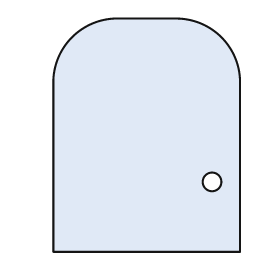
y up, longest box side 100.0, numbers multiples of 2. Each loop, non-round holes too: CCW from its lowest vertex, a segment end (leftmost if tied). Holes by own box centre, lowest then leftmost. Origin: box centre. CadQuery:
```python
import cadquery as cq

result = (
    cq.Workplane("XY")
    .moveTo(-40.0, -50.0)
    .lineTo(40.0, -50.0)
    .lineTo(40.0, 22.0)
    .threePointArc((32.0, 42.0), (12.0, 50.0))
    .lineTo(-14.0, 50.0)
    .threePointArc((-32.0, 42.0), (-40.0, 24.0))
    .close()
    .moveTo(28.0, -20.0)
    .circle(4.0)
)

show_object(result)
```